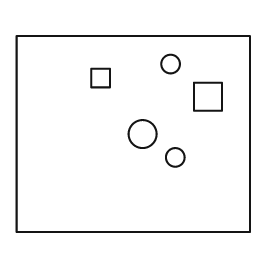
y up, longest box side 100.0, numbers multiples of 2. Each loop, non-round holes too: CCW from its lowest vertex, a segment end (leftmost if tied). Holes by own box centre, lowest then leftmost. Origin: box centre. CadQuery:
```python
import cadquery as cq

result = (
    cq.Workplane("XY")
    .moveTo(-50.0, -42.0)
    .lineTo(50.0, -42.0)
    .lineTo(50.0, 42.0)
    .lineTo(-50.0, 42.0)
    .close()
    .moveTo(18.0, -10.0)
    .circle(4.0)
    .moveTo(4.0, 0.0)
    .circle(6.0)
    .moveTo(26.0, 10.0)
    .lineTo(38.0, 10.0)
    .lineTo(38.0, 22.0)
    .lineTo(26.0, 22.0)
    .close()
    .moveTo(-18.0, 20.0)
    .lineTo(-10.0, 20.0)
    .lineTo(-10.0, 28.0)
    .lineTo(-18.0, 28.0)
    .close()
    .moveTo(16.0, 30.0)
    .circle(4.0)
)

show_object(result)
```